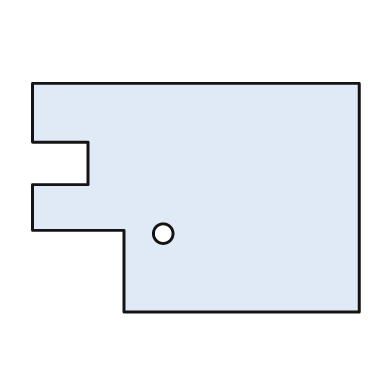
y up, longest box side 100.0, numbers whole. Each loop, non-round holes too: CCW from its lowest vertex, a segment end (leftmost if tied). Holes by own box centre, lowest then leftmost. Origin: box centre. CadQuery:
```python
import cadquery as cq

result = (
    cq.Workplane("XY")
    .moveTo(-22.0, -35.0)
    .lineTo(50.0, -35.0)
    .lineTo(50.0, 35.0)
    .lineTo(-50.0, 35.0)
    .lineTo(-50.0, 17.0)
    .lineTo(-33.0, 17.0)
    .lineTo(-33.0, 4.0)
    .lineTo(-50.0, 4.0)
    .lineTo(-50.0, -10.0)
    .lineTo(-22.0, -10.0)
    .close()
    .moveTo(-10.0, -11.0)
    .circle(3.0)
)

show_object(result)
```